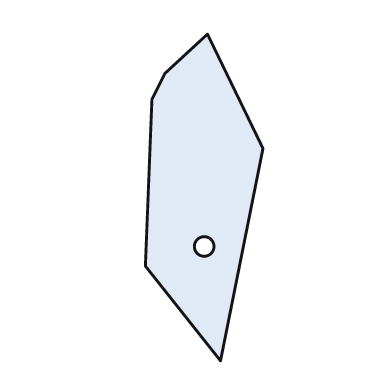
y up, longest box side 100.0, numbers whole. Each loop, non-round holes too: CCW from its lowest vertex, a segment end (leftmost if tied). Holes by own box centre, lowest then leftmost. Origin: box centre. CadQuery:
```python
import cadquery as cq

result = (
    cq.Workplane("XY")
    .moveTo(5.0, -50.0)
    .lineTo(18.0, 15.0)
    .lineTo(1.0, 50.0)
    .lineTo(-12.0, 38.0)
    .lineTo(-16.0, 30.0)
    .lineTo(-18.0, -21.0)
    .close()
    .moveTo(0.0, -15.0)
    .circle(3.0)
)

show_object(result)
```